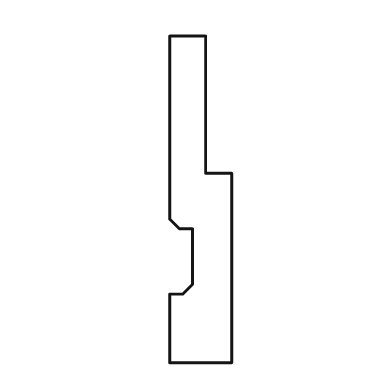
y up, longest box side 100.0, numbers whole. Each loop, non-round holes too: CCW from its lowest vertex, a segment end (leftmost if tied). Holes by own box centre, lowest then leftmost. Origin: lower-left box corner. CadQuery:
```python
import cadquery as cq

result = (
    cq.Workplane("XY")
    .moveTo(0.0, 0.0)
    .lineTo(19.0, 0.0)
    .lineTo(19.0, 58.0)
    .lineTo(11.0, 58.0)
    .lineTo(11.0, 100.0)
    .lineTo(0.0, 100.0)
    .lineTo(0.0, 44.0)
    .lineTo(3.0, 41.0)
    .lineTo(7.0, 41.0)
    .lineTo(7.0, 24.0)
    .lineTo(4.0, 21.0)
    .lineTo(0.0, 21.0)
    .close()
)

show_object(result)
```